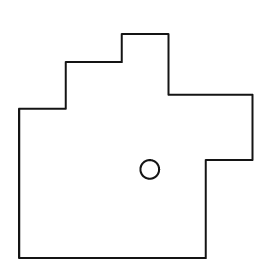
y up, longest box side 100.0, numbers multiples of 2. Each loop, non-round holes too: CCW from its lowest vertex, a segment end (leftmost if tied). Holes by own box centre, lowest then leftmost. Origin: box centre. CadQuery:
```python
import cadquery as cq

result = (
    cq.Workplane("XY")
    .moveTo(-50.0, -48.0)
    .lineTo(30.0, -48.0)
    .lineTo(30.0, -6.0)
    .lineTo(50.0, -6.0)
    .lineTo(50.0, 22.0)
    .lineTo(14.0, 22.0)
    .lineTo(14.0, 48.0)
    .lineTo(-6.0, 48.0)
    .lineTo(-6.0, 36.0)
    .lineTo(-30.0, 36.0)
    .lineTo(-30.0, 16.0)
    .lineTo(-50.0, 16.0)
    .close()
    .moveTo(6.0, -10.0)
    .circle(4.0)
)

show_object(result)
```